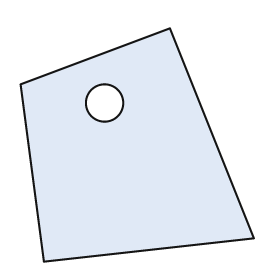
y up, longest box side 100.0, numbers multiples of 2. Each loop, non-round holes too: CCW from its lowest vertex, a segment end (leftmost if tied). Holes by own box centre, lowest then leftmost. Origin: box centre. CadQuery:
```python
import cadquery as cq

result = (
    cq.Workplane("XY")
    .moveTo(-40.0, -50.0)
    .lineTo(50.0, -40.0)
    .lineTo(14.0, 50.0)
    .lineTo(-50.0, 26.0)
    .close()
    .moveTo(-14.0, 18.0)
    .circle(8.0)
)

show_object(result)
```